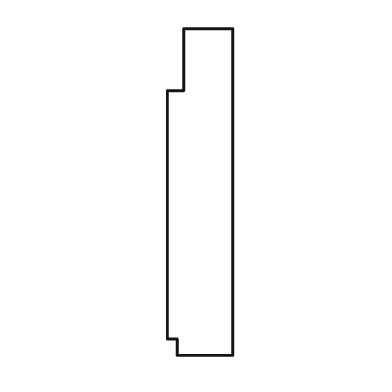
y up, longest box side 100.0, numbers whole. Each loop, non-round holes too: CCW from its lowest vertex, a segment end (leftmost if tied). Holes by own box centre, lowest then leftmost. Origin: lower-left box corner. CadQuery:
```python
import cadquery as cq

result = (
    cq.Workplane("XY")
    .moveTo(3.0, 0.0)
    .lineTo(20.0, 0.0)
    .lineTo(20.0, 100.0)
    .lineTo(5.0, 100.0)
    .lineTo(5.0, 81.0)
    .lineTo(0.0, 81.0)
    .lineTo(0.0, 5.0)
    .lineTo(3.0, 5.0)
    .close()
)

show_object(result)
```